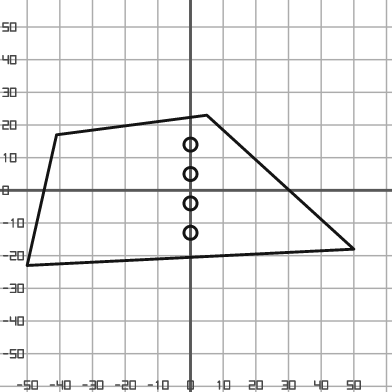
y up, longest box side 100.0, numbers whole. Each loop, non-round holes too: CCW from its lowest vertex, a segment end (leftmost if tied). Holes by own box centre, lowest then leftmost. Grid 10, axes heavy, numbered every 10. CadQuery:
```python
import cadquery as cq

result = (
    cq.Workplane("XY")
    .moveTo(-50.0, -23.0)
    .lineTo(50.0, -18.0)
    .lineTo(5.0, 23.0)
    .lineTo(-41.0, 17.0)
    .close()
    .moveTo(0.0, -13.0)
    .circle(2.0)
    .moveTo(0.0, -4.0)
    .circle(2.0)
    .moveTo(0.0, 5.0)
    .circle(2.0)
    .moveTo(0.0, 14.0)
    .circle(2.0)
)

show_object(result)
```